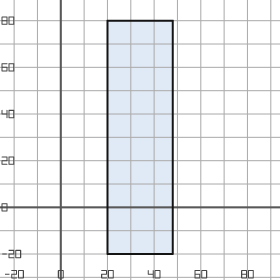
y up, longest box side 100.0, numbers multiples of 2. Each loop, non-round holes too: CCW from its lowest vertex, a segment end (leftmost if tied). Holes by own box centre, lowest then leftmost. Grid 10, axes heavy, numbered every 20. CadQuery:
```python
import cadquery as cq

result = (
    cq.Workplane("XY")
    .moveTo(20.0, -20.0)
    .lineTo(48.0, -20.0)
    .lineTo(48.0, 80.0)
    .lineTo(20.0, 80.0)
    .close()
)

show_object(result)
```